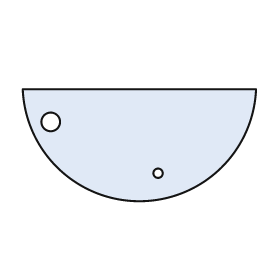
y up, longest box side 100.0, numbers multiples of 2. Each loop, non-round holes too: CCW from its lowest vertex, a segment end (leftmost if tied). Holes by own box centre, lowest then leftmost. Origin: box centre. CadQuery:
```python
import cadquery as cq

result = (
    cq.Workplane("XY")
    .moveTo(-50.0, 24.0)
    .threePointArc((0.0, -24.0), (50.0, 24.0))
    .close()
    .moveTo(8.0, -12.0)
    .circle(2.0)
    .moveTo(-38.0, 10.0)
    .circle(4.0)
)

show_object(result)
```